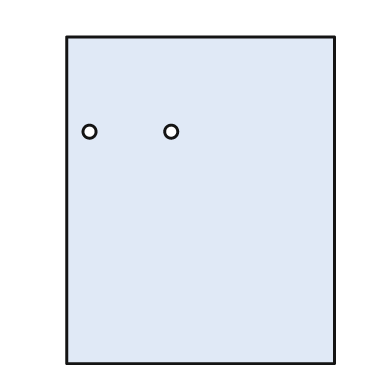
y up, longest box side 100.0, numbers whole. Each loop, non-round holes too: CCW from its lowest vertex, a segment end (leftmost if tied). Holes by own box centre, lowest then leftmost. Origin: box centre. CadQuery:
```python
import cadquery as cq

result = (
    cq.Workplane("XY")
    .moveTo(-41.0, -50.0)
    .lineTo(41.0, -50.0)
    .lineTo(41.0, 50.0)
    .lineTo(-41.0, 50.0)
    .close()
    .moveTo(-34.0, 21.0)
    .circle(2.0)
    .moveTo(-9.0, 21.0)
    .circle(2.0)
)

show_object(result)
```